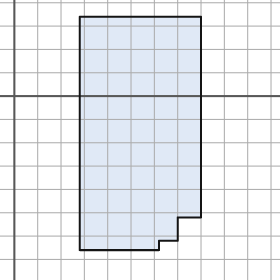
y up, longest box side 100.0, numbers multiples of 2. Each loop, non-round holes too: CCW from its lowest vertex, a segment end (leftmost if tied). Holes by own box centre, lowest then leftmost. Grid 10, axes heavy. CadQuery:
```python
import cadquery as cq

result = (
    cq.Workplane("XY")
    .moveTo(28.0, -66.0)
    .lineTo(62.0, -66.0)
    .lineTo(62.0, -62.0)
    .lineTo(70.0, -62.0)
    .lineTo(70.0, -52.0)
    .lineTo(80.0, -52.0)
    .lineTo(80.0, 34.0)
    .lineTo(28.0, 34.0)
    .close()
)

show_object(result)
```